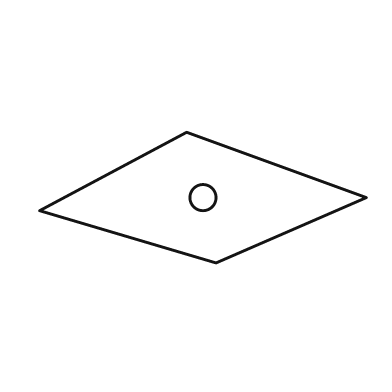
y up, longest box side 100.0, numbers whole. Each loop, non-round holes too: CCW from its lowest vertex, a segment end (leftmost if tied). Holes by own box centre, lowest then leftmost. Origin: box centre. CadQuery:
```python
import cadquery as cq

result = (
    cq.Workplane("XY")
    .moveTo(4.0, -20.0)
    .lineTo(50.0, 0.0)
    .lineTo(-5.0, 20.0)
    .lineTo(-50.0, -4.0)
    .close()
    .moveTo(0.0, 0.0)
    .circle(4.0)
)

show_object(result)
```